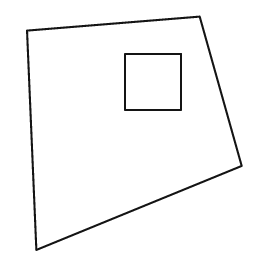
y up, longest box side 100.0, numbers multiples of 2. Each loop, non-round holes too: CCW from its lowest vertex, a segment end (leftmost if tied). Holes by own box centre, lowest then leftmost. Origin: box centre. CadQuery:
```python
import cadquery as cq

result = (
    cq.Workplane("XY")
    .moveTo(-42.0, -50.0)
    .lineTo(46.0, -14.0)
    .lineTo(28.0, 50.0)
    .lineTo(-46.0, 44.0)
    .close()
    .moveTo(-4.0, 10.0)
    .lineTo(20.0, 10.0)
    .lineTo(20.0, 34.0)
    .lineTo(-4.0, 34.0)
    .close()
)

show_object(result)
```